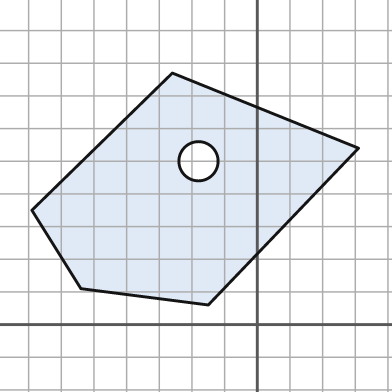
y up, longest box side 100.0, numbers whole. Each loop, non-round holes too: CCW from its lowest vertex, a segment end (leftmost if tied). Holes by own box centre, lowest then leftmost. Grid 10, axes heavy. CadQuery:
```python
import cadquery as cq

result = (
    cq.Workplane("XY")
    .moveTo(-15.0, 6.0)
    .lineTo(31.0, 54.0)
    .lineTo(-26.0, 77.0)
    .lineTo(-69.0, 35.0)
    .lineTo(-54.0, 11.0)
    .close()
    .moveTo(-18.0, 50.0)
    .circle(6.0)
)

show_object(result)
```